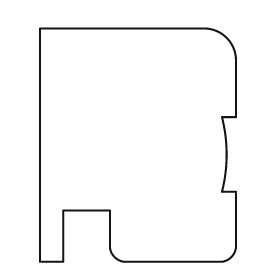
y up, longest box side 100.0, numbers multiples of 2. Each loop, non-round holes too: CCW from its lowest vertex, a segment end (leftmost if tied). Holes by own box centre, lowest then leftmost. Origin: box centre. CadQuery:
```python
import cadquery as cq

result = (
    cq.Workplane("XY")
    .moveTo(-42.0, -50.0)
    .lineTo(-32.0, -50.0)
    .lineTo(-32.0, -28.0)
    .lineTo(-12.0, -28.0)
    .lineTo(-12.0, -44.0)
    .threePointArc((-10.0, -48.0), (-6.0, -50.0))
    .lineTo(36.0, -50.0)
    .threePointArc((40.0, -48.0), (42.0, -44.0))
    .lineTo(42.0, -20.0)
    .lineTo(36.0, -20.0)
    .threePointArc((38.0, -4.0), (36.0, 12.0))
    .lineTo(42.0, 12.0)
    .lineTo(42.0, 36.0)
    .threePointArc((38.0, 46.0), (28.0, 50.0))
    .lineTo(-42.0, 50.0)
    .close()
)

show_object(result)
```